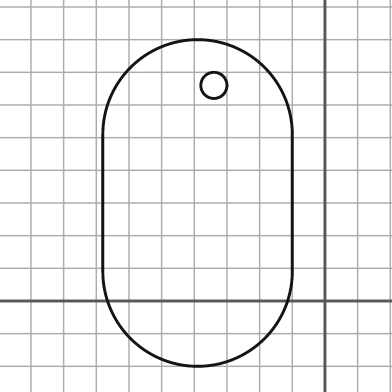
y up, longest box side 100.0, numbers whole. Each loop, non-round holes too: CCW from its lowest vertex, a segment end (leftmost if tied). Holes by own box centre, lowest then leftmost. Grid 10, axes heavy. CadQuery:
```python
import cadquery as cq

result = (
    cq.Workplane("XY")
    .moveTo(-68.0, 9.0)
    .threePointArc((-39.0, -20.0), (-10.0, 9.0))
    .lineTo(-10.0, 51.0)
    .threePointArc((-39.0, 80.0), (-68.0, 51.0))
    .close()
    .moveTo(-34.0, 66.0)
    .circle(4.0)
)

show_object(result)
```